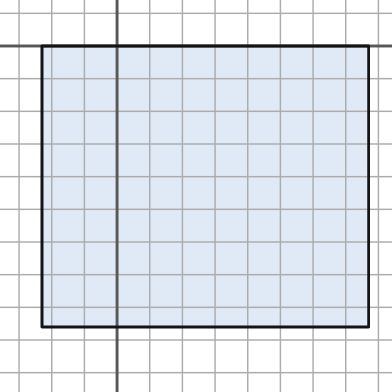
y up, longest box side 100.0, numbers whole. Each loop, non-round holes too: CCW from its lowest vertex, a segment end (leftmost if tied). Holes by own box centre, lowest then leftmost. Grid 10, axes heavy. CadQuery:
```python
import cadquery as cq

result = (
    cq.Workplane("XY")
    .moveTo(-23.0, -86.0)
    .lineTo(77.0, -86.0)
    .lineTo(77.0, 0.0)
    .lineTo(-23.0, 0.0)
    .close()
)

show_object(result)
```